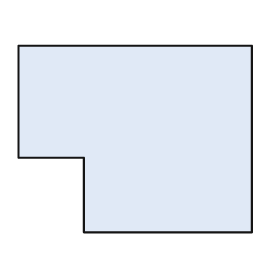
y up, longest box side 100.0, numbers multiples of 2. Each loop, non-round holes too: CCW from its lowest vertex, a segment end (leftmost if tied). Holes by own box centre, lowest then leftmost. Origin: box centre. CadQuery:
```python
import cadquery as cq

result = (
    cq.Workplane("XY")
    .moveTo(-22.0, -40.0)
    .lineTo(50.0, -40.0)
    .lineTo(50.0, 40.0)
    .lineTo(-50.0, 40.0)
    .lineTo(-50.0, -8.0)
    .lineTo(-22.0, -8.0)
    .close()
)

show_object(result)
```